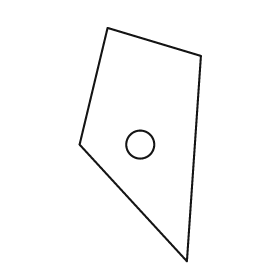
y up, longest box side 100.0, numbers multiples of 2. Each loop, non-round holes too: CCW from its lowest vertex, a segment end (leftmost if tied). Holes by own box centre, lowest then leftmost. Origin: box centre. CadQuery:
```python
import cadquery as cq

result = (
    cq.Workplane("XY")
    .moveTo(20.0, -50.0)
    .lineTo(26.0, 38.0)
    .lineTo(-14.0, 50.0)
    .lineTo(-26.0, 0.0)
    .close()
    .moveTo(0.0, 0.0)
    .circle(6.0)
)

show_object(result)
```